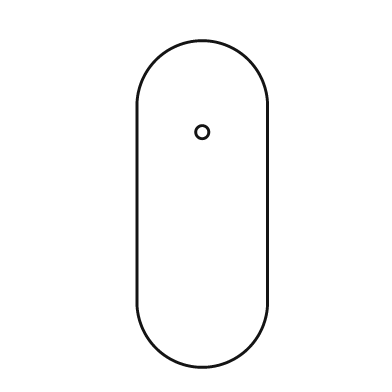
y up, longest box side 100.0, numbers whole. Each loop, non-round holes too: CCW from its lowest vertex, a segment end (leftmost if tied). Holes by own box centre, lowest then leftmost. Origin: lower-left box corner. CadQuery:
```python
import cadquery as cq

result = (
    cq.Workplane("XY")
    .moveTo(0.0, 20.0)
    .threePointArc((20.0, 0.0), (40.0, 20.0))
    .lineTo(40.0, 80.0)
    .threePointArc((20.0, 100.0), (0.0, 80.0))
    .close()
    .moveTo(20.0, 72.0)
    .circle(2.0)
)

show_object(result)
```